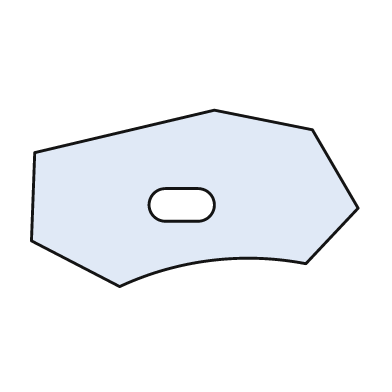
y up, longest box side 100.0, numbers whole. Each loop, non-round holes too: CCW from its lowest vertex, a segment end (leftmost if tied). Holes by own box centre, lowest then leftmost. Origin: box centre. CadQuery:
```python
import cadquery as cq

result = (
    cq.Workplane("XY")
    .moveTo(-23.0, -27.0)
    .threePointArc((5.0, -19.0), (34.0, -20.0))
    .lineTo(50.0, -3.0)
    .lineTo(36.0, 21.0)
    .lineTo(6.0, 27.0)
    .lineTo(-49.0, 14.0)
    .lineTo(-50.0, -13.0)
    .close()
    .moveTo(-9.0, -7.0)
    .lineTo(1.0, -7.0)
    .threePointArc((6.0, -2.0), (1.0, 3.0))
    .lineTo(-9.0, 3.0)
    .threePointArc((-14.0, -2.0), (-9.0, -7.0))
    .close()
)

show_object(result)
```